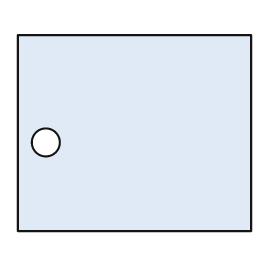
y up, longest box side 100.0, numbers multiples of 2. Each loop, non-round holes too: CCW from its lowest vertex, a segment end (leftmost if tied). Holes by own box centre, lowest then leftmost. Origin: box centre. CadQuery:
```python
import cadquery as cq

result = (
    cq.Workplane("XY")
    .moveTo(-50.0, -42.0)
    .lineTo(50.0, -42.0)
    .lineTo(50.0, 42.0)
    .lineTo(-50.0, 42.0)
    .close()
    .moveTo(-38.0, -4.0)
    .circle(6.0)
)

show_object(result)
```